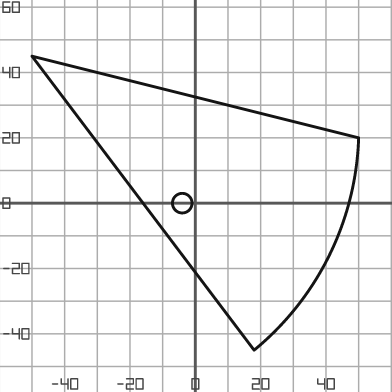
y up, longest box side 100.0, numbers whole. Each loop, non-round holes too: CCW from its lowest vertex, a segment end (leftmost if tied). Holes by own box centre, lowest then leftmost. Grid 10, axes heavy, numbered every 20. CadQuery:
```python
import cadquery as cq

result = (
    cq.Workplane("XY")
    .moveTo(18.0, -45.0)
    .threePointArc((41.0, -16.0), (50.0, 20.0))
    .lineTo(-50.0, 45.0)
    .close()
    .moveTo(-4.0, 0.0)
    .circle(3.0)
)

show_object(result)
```